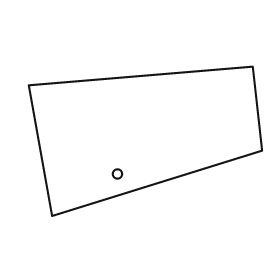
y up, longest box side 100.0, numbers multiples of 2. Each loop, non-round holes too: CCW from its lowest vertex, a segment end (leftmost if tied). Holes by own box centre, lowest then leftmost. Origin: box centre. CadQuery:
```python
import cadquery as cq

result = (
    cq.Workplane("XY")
    .moveTo(-40.0, -32.0)
    .lineTo(50.0, -4.0)
    .lineTo(46.0, 32.0)
    .lineTo(-50.0, 24.0)
    .close()
    .moveTo(-12.0, -14.0)
    .circle(2.0)
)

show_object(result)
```